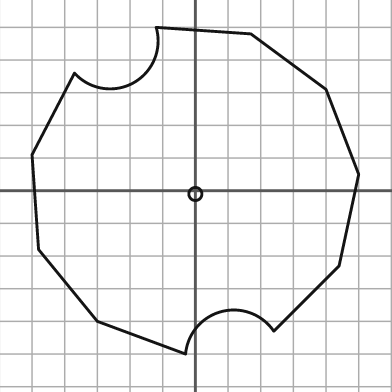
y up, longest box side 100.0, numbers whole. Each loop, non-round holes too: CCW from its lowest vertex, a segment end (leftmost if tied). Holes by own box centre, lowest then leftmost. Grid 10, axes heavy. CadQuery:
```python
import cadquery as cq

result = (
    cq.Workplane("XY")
    .moveTo(-3.0, -50.0)
    .threePointArc((8.0, -37.0), (24.0, -43.0))
    .lineTo(44.0, -23.0)
    .lineTo(50.0, 5.0)
    .lineTo(40.0, 31.0)
    .lineTo(17.0, 48.0)
    .lineTo(-12.0, 50.0)
    .threePointArc((-19.0, 33.0), (-37.0, 36.0))
    .lineTo(-50.0, 11.0)
    .lineTo(-48.0, -18.0)
    .lineTo(-30.0, -40.0)
    .close()
    .moveTo(0.0, -1.0)
    .circle(2.0)
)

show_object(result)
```